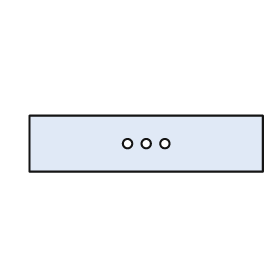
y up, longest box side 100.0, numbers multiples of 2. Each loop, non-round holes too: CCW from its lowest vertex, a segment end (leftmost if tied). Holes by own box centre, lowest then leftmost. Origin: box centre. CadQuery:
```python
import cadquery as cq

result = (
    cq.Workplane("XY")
    .moveTo(-50.0, -12.0)
    .lineTo(50.0, -12.0)
    .lineTo(50.0, 12.0)
    .lineTo(-50.0, 12.0)
    .close()
    .moveTo(-8.0, 0.0)
    .circle(2.0)
    .moveTo(0.0, 0.0)
    .circle(2.0)
    .moveTo(8.0, 0.0)
    .circle(2.0)
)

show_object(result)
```